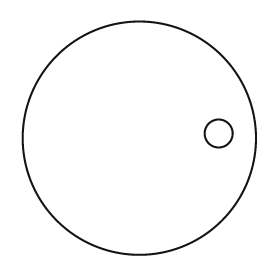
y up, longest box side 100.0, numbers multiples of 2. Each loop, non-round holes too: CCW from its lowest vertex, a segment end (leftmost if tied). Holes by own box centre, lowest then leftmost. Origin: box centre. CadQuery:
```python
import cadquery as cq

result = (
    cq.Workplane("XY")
    .moveTo(0.0, 0.0)
    .circle(50.0)
    .moveTo(34.0, 2.0)
    .circle(6.0)
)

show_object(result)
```